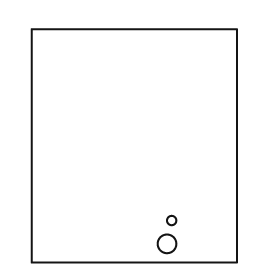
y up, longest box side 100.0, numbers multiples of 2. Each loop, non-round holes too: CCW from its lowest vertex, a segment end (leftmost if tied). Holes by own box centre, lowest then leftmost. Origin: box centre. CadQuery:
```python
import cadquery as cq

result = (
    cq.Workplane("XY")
    .moveTo(-44.0, -50.0)
    .lineTo(44.0, -50.0)
    .lineTo(44.0, 50.0)
    .lineTo(-44.0, 50.0)
    .close()
    .moveTo(14.0, -42.0)
    .circle(4.0)
    .moveTo(16.0, -32.0)
    .circle(2.0)
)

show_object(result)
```